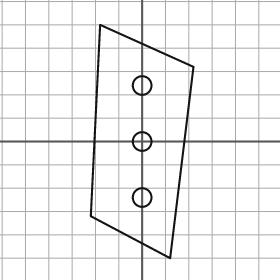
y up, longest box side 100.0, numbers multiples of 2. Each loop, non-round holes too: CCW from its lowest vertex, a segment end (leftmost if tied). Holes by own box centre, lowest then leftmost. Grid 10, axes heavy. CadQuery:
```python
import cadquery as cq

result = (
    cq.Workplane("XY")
    .moveTo(12.0, -50.0)
    .lineTo(22.0, 32.0)
    .lineTo(-18.0, 50.0)
    .lineTo(-22.0, -32.0)
    .close()
    .moveTo(0.0, -24.0)
    .circle(4.0)
    .moveTo(0.0, 0.0)
    .circle(4.0)
    .moveTo(0.0, 24.0)
    .circle(4.0)
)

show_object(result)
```